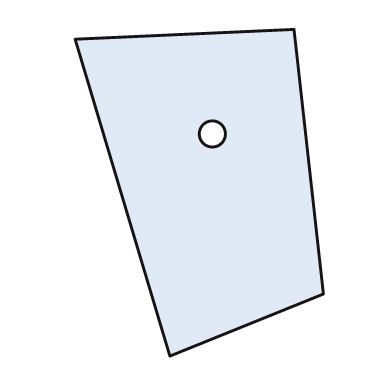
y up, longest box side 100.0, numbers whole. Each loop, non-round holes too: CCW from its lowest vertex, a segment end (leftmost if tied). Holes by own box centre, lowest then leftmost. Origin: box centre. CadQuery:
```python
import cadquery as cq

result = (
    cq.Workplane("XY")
    .moveTo(-9.0, -50.0)
    .lineTo(38.0, -31.0)
    .lineTo(29.0, 50.0)
    .lineTo(-38.0, 47.0)
    .close()
    .moveTo(4.0, 18.0)
    .circle(4.0)
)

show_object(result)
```